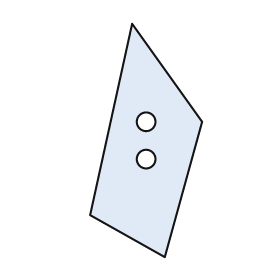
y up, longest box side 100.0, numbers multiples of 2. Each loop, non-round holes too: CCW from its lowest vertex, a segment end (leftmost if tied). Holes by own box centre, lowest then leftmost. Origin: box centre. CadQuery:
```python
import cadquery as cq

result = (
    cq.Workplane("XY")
    .moveTo(8.0, -50.0)
    .lineTo(24.0, 8.0)
    .lineTo(-6.0, 50.0)
    .lineTo(-24.0, -32.0)
    .close()
    .moveTo(0.0, -8.0)
    .circle(4.0)
    .moveTo(0.0, 8.0)
    .circle(4.0)
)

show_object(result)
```